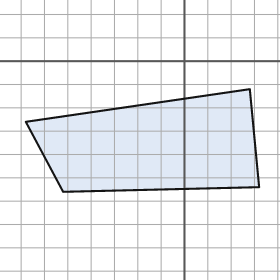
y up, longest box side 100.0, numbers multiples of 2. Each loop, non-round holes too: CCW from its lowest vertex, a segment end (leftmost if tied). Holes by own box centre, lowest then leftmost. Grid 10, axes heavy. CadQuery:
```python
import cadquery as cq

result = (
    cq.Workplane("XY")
    .moveTo(-52.0, -56.0)
    .lineTo(32.0, -54.0)
    .lineTo(28.0, -12.0)
    .lineTo(-68.0, -26.0)
    .close()
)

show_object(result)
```